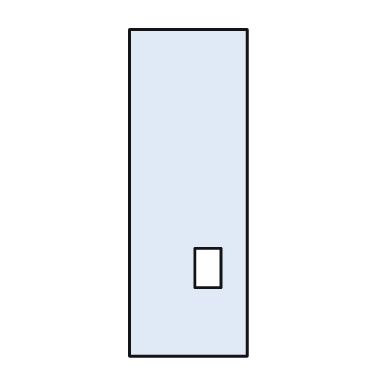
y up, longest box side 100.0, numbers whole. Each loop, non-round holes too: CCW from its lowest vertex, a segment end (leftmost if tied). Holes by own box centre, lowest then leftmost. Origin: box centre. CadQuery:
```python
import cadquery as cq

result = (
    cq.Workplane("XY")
    .moveTo(-18.0, -50.0)
    .lineTo(18.0, -50.0)
    .lineTo(18.0, 50.0)
    .lineTo(-18.0, 50.0)
    .close()
    .moveTo(2.0, -29.0)
    .lineTo(10.0, -29.0)
    .lineTo(10.0, -17.0)
    .lineTo(2.0, -17.0)
    .close()
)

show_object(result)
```